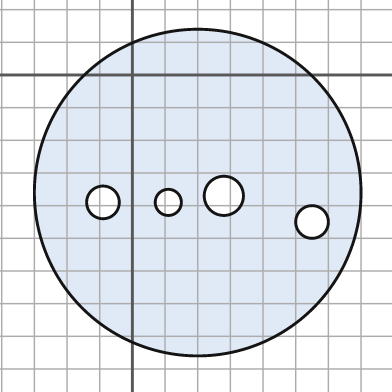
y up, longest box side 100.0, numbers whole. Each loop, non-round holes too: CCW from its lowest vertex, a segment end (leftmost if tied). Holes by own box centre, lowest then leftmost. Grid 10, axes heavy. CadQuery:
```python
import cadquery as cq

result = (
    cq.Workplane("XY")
    .moveTo(20.0, -36.0)
    .circle(50.0)
    .moveTo(55.0, -45.0)
    .circle(5.0)
    .moveTo(-9.0, -39.0)
    .circle(5.0)
    .moveTo(11.0, -39.0)
    .circle(4.0)
    .moveTo(28.0, -37.0)
    .circle(6.0)
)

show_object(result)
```